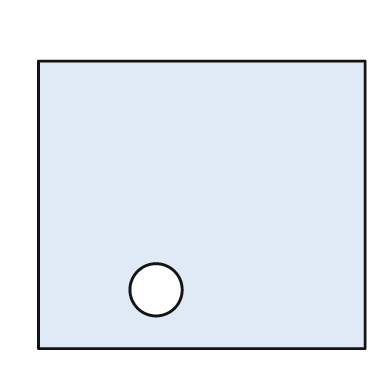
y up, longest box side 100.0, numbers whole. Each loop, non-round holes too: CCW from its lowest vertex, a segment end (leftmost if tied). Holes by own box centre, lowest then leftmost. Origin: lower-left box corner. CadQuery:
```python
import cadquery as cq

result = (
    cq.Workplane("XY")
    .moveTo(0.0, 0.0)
    .lineTo(100.0, 0.0)
    .lineTo(100.0, 88.0)
    .lineTo(0.0, 88.0)
    .close()
    .moveTo(36.0, 18.0)
    .circle(8.0)
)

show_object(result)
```